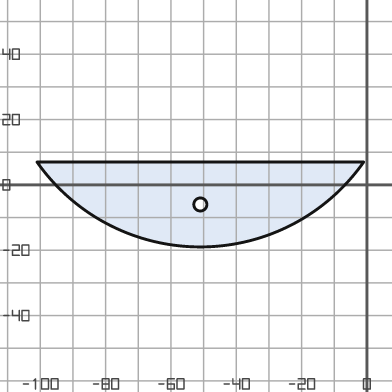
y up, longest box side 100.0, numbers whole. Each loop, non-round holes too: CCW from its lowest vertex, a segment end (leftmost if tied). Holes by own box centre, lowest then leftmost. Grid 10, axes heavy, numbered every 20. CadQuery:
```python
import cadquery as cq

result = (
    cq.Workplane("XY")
    .moveTo(-101.0, 7.0)
    .threePointArc((-51.0, -19.0), (-1.0, 7.0))
    .close()
    .moveTo(-51.0, -6.0)
    .circle(2.0)
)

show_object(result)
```